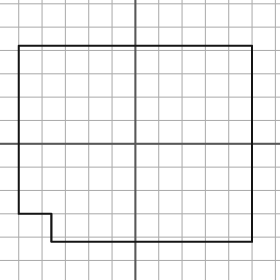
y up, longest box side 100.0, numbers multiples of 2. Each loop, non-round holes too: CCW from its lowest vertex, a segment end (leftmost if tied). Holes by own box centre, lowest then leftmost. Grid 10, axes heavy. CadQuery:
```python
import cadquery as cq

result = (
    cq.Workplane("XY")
    .moveTo(-36.0, -42.0)
    .lineTo(50.0, -42.0)
    .lineTo(50.0, 42.0)
    .lineTo(-50.0, 42.0)
    .lineTo(-50.0, -30.0)
    .lineTo(-36.0, -30.0)
    .close()
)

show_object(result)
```